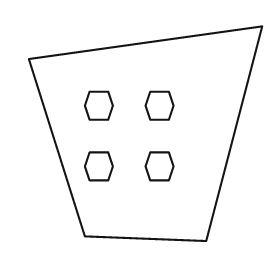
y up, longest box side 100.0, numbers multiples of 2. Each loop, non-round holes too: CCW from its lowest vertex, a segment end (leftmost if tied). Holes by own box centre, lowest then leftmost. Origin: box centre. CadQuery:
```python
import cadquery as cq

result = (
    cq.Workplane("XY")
    .moveTo(26.0, -46.0)
    .lineTo(50.0, 46.0)
    .lineTo(-50.0, 32.0)
    .lineTo(-26.0, -44.0)
    .close()
    .moveTo(-24.0, -20.0)
    .lineTo(-16.0, -20.0)
    .lineTo(-14.0, -14.0)
    .lineTo(-16.0, -8.0)
    .lineTo(-24.0, -8.0)
    .lineTo(-26.0, -14.0)
    .close()
    .moveTo(2.0, -20.0)
    .lineTo(10.0, -20.0)
    .lineTo(12.0, -14.0)
    .lineTo(10.0, -8.0)
    .lineTo(2.0, -8.0)
    .lineTo(0.0, -14.0)
    .close()
    .moveTo(-24.0, 6.0)
    .lineTo(-16.0, 6.0)
    .lineTo(-14.0, 12.0)
    .lineTo(-16.0, 18.0)
    .lineTo(-24.0, 18.0)
    .lineTo(-26.0, 12.0)
    .close()
    .moveTo(2.0, 6.0)
    .lineTo(10.0, 6.0)
    .lineTo(12.0, 12.0)
    .lineTo(10.0, 18.0)
    .lineTo(2.0, 18.0)
    .lineTo(0.0, 12.0)
    .close()
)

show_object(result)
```